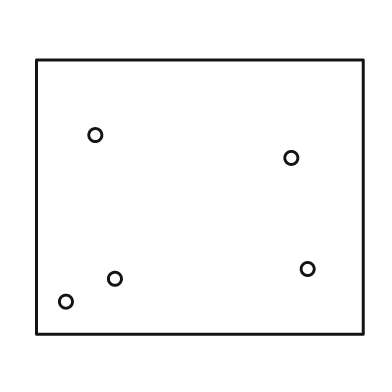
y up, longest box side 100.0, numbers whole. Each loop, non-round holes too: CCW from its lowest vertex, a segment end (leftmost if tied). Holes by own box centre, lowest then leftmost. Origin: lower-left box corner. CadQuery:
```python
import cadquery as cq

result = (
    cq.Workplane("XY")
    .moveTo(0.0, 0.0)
    .lineTo(100.0, 0.0)
    .lineTo(100.0, 84.0)
    .lineTo(0.0, 84.0)
    .close()
    .moveTo(9.0, 10.0)
    .circle(2.0)
    .moveTo(24.0, 17.0)
    .circle(2.0)
    .moveTo(83.0, 20.0)
    .circle(2.0)
    .moveTo(78.0, 54.0)
    .circle(2.0)
    .moveTo(18.0, 61.0)
    .circle(2.0)
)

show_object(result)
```